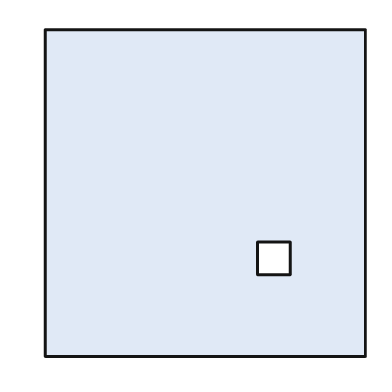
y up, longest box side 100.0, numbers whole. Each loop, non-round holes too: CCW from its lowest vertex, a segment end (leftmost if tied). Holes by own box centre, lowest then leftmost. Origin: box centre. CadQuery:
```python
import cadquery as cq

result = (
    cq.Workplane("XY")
    .moveTo(-49.0, -50.0)
    .lineTo(49.0, -50.0)
    .lineTo(49.0, 50.0)
    .lineTo(-49.0, 50.0)
    .close()
    .moveTo(16.0, -25.0)
    .lineTo(26.0, -25.0)
    .lineTo(26.0, -15.0)
    .lineTo(16.0, -15.0)
    .close()
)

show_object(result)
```